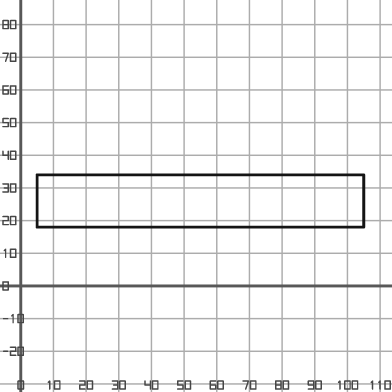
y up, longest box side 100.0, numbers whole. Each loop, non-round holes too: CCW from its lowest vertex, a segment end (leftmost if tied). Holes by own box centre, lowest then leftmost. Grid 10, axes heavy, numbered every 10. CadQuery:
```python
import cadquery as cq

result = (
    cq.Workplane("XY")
    .moveTo(5.0, 18.0)
    .lineTo(105.0, 18.0)
    .lineTo(105.0, 34.0)
    .lineTo(5.0, 34.0)
    .close()
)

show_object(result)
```